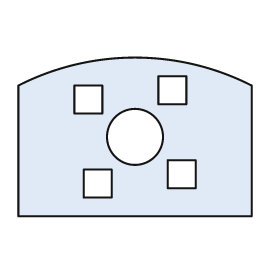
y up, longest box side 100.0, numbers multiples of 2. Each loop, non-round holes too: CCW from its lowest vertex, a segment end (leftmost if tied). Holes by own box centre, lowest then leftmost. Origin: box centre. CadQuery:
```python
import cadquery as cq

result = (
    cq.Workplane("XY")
    .moveTo(-50.0, -34.0)
    .lineTo(50.0, -34.0)
    .lineTo(50.0, 22.0)
    .threePointArc((0.0, 34.0), (-50.0, 22.0))
    .close()
    .moveTo(-22.0, -26.0)
    .lineTo(-10.0, -26.0)
    .lineTo(-10.0, -14.0)
    .lineTo(-22.0, -14.0)
    .close()
    .moveTo(14.0, -22.0)
    .lineTo(26.0, -22.0)
    .lineTo(26.0, -10.0)
    .lineTo(14.0, -10.0)
    .close()
    .moveTo(0.0, 0.0)
    .circle(12.0)
    .moveTo(-26.0, 10.0)
    .lineTo(-14.0, 10.0)
    .lineTo(-14.0, 22.0)
    .lineTo(-26.0, 22.0)
    .close()
    .moveTo(10.0, 14.0)
    .lineTo(22.0, 14.0)
    .lineTo(22.0, 26.0)
    .lineTo(10.0, 26.0)
    .close()
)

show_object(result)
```